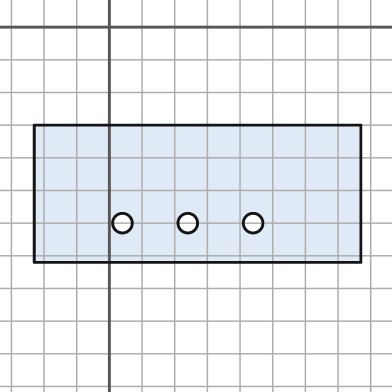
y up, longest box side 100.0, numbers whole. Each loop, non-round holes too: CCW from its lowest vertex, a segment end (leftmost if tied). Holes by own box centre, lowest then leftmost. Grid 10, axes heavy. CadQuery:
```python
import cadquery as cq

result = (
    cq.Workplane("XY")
    .moveTo(-23.0, -72.0)
    .lineTo(77.0, -72.0)
    .lineTo(77.0, -30.0)
    .lineTo(-23.0, -30.0)
    .close()
    .moveTo(4.0, -60.0)
    .circle(3.0)
    .moveTo(24.0, -60.0)
    .circle(3.0)
    .moveTo(44.0, -60.0)
    .circle(3.0)
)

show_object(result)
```